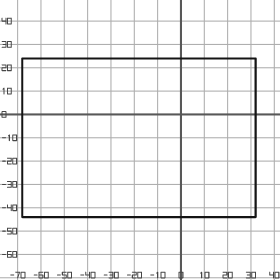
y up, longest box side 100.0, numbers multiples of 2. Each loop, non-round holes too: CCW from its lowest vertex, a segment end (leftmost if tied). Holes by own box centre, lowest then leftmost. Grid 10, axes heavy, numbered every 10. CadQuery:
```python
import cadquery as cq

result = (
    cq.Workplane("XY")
    .moveTo(-68.0, -44.0)
    .lineTo(32.0, -44.0)
    .lineTo(32.0, 24.0)
    .lineTo(-68.0, 24.0)
    .close()
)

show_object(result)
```